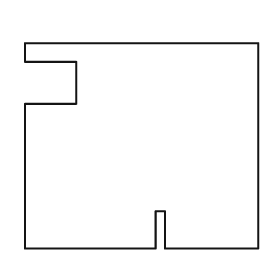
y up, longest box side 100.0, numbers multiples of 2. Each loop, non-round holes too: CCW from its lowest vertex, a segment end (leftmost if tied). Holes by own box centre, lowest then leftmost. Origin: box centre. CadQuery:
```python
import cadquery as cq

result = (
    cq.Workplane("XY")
    .moveTo(-50.0, -44.0)
    .lineTo(6.0, -44.0)
    .lineTo(6.0, -28.0)
    .lineTo(10.0, -28.0)
    .lineTo(10.0, -44.0)
    .lineTo(50.0, -44.0)
    .lineTo(50.0, 44.0)
    .lineTo(-50.0, 44.0)
    .lineTo(-50.0, 36.0)
    .lineTo(-28.0, 36.0)
    .lineTo(-28.0, 18.0)
    .lineTo(-50.0, 18.0)
    .close()
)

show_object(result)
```